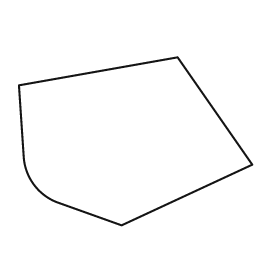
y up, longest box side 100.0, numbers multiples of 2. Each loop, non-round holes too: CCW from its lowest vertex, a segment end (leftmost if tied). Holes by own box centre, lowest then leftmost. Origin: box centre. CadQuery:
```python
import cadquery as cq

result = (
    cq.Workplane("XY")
    .moveTo(-6.0, -36.0)
    .lineTo(50.0, -10.0)
    .lineTo(18.0, 36.0)
    .lineTo(-50.0, 24.0)
    .lineTo(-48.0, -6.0)
    .threePointArc((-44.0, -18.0), (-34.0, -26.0))
    .close()
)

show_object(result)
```